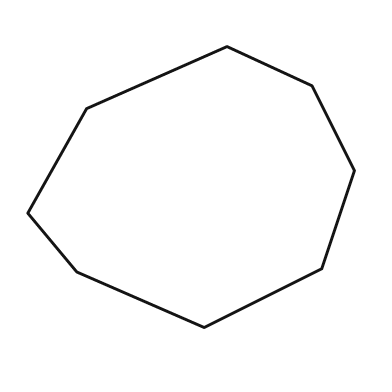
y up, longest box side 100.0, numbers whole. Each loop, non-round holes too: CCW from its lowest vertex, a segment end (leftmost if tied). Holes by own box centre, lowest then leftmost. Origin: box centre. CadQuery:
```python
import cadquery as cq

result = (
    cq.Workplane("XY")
    .moveTo(4.0, -43.0)
    .lineTo(40.0, -25.0)
    .lineTo(50.0, 5.0)
    .lineTo(37.0, 31.0)
    .lineTo(11.0, 43.0)
    .lineTo(-32.0, 24.0)
    .lineTo(-50.0, -8.0)
    .lineTo(-35.0, -26.0)
    .close()
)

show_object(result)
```